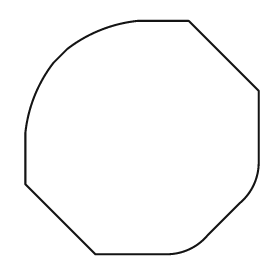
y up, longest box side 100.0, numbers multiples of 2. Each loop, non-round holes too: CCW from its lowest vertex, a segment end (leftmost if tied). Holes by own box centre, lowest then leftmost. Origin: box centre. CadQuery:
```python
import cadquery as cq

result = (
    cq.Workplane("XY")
    .moveTo(-20.0, -50.0)
    .lineTo(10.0, -50.0)
    .threePointArc((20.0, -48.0), (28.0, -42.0))
    .lineTo(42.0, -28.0)
    .threePointArc((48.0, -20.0), (50.0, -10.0))
    .lineTo(50.0, 20.0)
    .lineTo(20.0, 50.0)
    .lineTo(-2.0, 50.0)
    .threePointArc((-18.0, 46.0), (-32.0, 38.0))
    .lineTo(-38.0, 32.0)
    .threePointArc((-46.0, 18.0), (-50.0, 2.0))
    .lineTo(-50.0, -20.0)
    .close()
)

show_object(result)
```